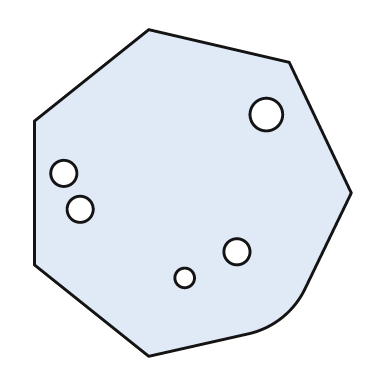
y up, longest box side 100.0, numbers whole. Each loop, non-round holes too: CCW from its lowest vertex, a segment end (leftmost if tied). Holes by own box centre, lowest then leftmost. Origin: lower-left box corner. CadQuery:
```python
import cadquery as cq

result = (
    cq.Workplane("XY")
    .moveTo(35.0, 0.0)
    .lineTo(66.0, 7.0)
    .threePointArc((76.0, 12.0), (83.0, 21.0))
    .lineTo(97.0, 50.0)
    .lineTo(78.0, 90.0)
    .lineTo(35.0, 100.0)
    .lineTo(0.0, 72.0)
    .lineTo(0.0, 28.0)
    .close()
    .moveTo(46.0, 24.0)
    .circle(3.0)
    .moveTo(62.0, 32.0)
    .circle(4.0)
    .moveTo(14.0, 45.0)
    .circle(4.0)
    .moveTo(9.0, 56.0)
    .circle(4.0)
    .moveTo(71.0, 74.0)
    .circle(5.0)
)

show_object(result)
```